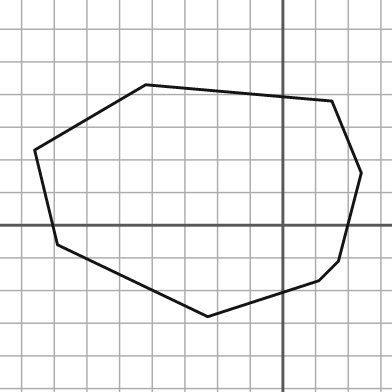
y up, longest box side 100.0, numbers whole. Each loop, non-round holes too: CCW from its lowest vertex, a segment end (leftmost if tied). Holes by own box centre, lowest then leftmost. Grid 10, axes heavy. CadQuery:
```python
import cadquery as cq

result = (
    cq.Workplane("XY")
    .moveTo(-23.0, -28.0)
    .lineTo(11.0, -17.0)
    .lineTo(17.0, -11.0)
    .lineTo(24.0, 16.0)
    .lineTo(15.0, 38.0)
    .lineTo(-42.0, 43.0)
    .lineTo(-76.0, 23.0)
    .lineTo(-69.0, -6.0)
    .close()
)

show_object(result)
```